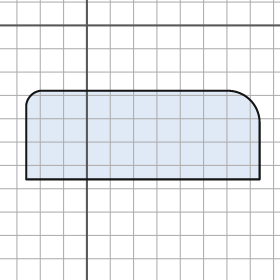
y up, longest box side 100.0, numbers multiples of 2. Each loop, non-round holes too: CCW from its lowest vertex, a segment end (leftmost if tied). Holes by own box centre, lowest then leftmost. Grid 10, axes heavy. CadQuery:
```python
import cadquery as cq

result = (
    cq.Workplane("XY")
    .moveTo(-26.0, -66.0)
    .lineTo(74.0, -66.0)
    .lineTo(74.0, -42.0)
    .threePointArc((70.0, -32.0), (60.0, -28.0))
    .lineTo(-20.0, -28.0)
    .threePointArc((-24.0, -30.0), (-26.0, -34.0))
    .close()
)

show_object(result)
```